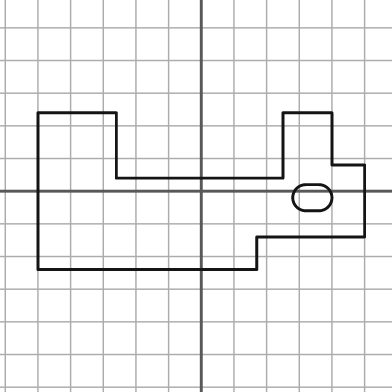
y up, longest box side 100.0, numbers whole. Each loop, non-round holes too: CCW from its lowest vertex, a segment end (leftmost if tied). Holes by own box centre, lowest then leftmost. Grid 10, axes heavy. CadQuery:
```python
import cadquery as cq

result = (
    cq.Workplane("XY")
    .moveTo(-50.0, -24.0)
    .lineTo(17.0, -24.0)
    .lineTo(17.0, -14.0)
    .lineTo(50.0, -14.0)
    .lineTo(50.0, 8.0)
    .lineTo(40.0, 8.0)
    .lineTo(40.0, 24.0)
    .lineTo(25.0, 24.0)
    .lineTo(25.0, 4.0)
    .lineTo(-26.0, 4.0)
    .lineTo(-26.0, 24.0)
    .lineTo(-50.0, 24.0)
    .close()
    .moveTo(32.0, -6.0)
    .lineTo(36.0, -6.0)
    .threePointArc((40.0, -2.0), (36.0, 2.0))
    .lineTo(32.0, 2.0)
    .threePointArc((28.0, -2.0), (32.0, -6.0))
    .close()
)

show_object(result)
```